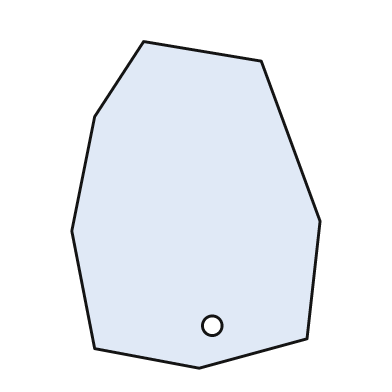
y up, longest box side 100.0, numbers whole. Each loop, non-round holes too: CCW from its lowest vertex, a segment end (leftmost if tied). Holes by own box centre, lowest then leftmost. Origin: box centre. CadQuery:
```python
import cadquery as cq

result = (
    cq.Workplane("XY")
    .moveTo(1.0, -50.0)
    .lineTo(34.0, -41.0)
    .lineTo(38.0, -5.0)
    .lineTo(20.0, 44.0)
    .lineTo(-16.0, 50.0)
    .lineTo(-31.0, 27.0)
    .lineTo(-38.0, -8.0)
    .lineTo(-31.0, -44.0)
    .close()
    .moveTo(5.0, -37.0)
    .circle(3.0)
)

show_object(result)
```